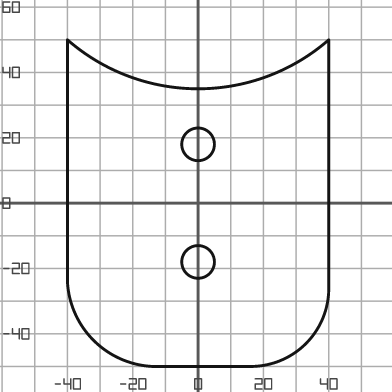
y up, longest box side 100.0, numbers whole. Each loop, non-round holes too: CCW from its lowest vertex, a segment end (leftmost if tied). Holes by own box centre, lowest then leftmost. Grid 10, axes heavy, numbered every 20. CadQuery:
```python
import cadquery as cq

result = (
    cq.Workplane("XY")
    .moveTo(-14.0, -50.0)
    .lineTo(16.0, -50.0)
    .threePointArc((33.0, -43.0), (40.0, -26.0))
    .lineTo(40.0, 50.0)
    .threePointArc((0.0, 35.0), (-40.0, 50.0))
    .lineTo(-40.0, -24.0)
    .threePointArc((-32.0, -42.0), (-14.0, -50.0))
    .close()
    .moveTo(0.0, -18.0)
    .circle(5.0)
    .moveTo(0.0, 18.0)
    .circle(5.0)
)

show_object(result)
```